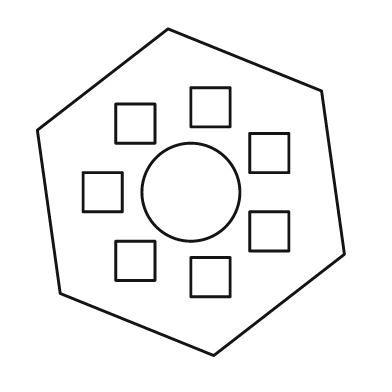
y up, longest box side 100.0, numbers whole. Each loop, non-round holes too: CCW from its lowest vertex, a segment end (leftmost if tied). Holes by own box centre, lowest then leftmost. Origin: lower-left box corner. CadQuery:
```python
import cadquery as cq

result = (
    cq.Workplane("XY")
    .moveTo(54.0, 0.0)
    .lineTo(94.0, 31.0)
    .lineTo(87.0, 81.0)
    .lineTo(40.0, 100.0)
    .lineTo(0.0, 69.0)
    .lineTo(7.0, 19.0)
    .close()
    .moveTo(47.0, 18.0)
    .lineTo(59.0, 18.0)
    .lineTo(59.0, 30.0)
    .lineTo(47.0, 30.0)
    .close()
    .moveTo(24.0, 23.0)
    .lineTo(36.0, 23.0)
    .lineTo(36.0, 35.0)
    .lineTo(24.0, 35.0)
    .close()
    .moveTo(65.0, 32.0)
    .lineTo(77.0, 32.0)
    .lineTo(77.0, 44.0)
    .lineTo(65.0, 44.0)
    .close()
    .moveTo(14.0, 44.0)
    .lineTo(26.0, 44.0)
    .lineTo(26.0, 56.0)
    .lineTo(14.0, 56.0)
    .close()
    .moveTo(47.0, 50.0)
    .circle(15.0)
    .moveTo(65.0, 56.0)
    .lineTo(77.0, 56.0)
    .lineTo(77.0, 68.0)
    .lineTo(65.0, 68.0)
    .close()
    .moveTo(24.0, 65.0)
    .lineTo(36.0, 65.0)
    .lineTo(36.0, 77.0)
    .lineTo(24.0, 77.0)
    .close()
    .moveTo(47.0, 70.0)
    .lineTo(59.0, 70.0)
    .lineTo(59.0, 82.0)
    .lineTo(47.0, 82.0)
    .close()
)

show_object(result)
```